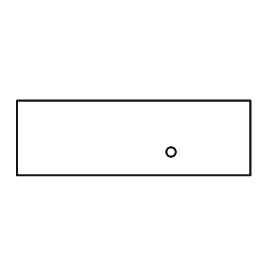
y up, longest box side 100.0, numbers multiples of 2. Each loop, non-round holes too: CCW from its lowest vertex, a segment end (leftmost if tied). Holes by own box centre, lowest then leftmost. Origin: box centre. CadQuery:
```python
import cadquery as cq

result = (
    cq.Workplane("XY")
    .moveTo(-50.0, -16.0)
    .lineTo(50.0, -16.0)
    .lineTo(50.0, 16.0)
    .lineTo(-50.0, 16.0)
    .close()
    .moveTo(16.0, -6.0)
    .circle(2.0)
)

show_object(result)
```